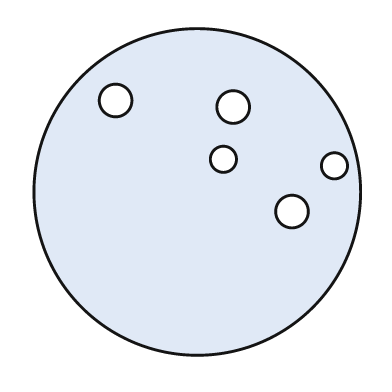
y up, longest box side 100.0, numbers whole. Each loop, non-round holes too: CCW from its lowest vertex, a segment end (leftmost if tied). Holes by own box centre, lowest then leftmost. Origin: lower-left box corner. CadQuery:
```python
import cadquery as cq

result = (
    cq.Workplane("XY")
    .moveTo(50.0, 50.0)
    .circle(50.0)
    .moveTo(79.0, 44.0)
    .circle(5.0)
    .moveTo(92.0, 58.0)
    .circle(4.0)
    .moveTo(58.0, 60.0)
    .circle(4.0)
    .moveTo(61.0, 76.0)
    .circle(5.0)
    .moveTo(25.0, 78.0)
    .circle(5.0)
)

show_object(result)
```